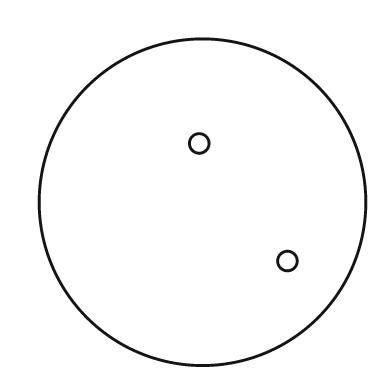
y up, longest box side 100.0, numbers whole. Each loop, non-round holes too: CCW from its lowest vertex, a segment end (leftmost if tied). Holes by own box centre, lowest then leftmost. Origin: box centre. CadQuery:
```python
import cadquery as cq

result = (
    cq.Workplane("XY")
    .moveTo(0.0, 0.0)
    .circle(50.0)
    .moveTo(26.0, -18.0)
    .circle(3.0)
    .moveTo(-1.0, 18.0)
    .circle(3.0)
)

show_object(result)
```